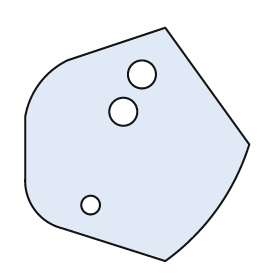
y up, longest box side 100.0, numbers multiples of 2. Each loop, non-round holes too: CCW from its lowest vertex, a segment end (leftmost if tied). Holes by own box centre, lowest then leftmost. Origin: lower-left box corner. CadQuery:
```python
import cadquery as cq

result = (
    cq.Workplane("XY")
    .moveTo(60.0, 0.0)
    .threePointArc((82.0, 22.0), (96.0, 50.0))
    .lineTo(60.0, 100.0)
    .lineTo(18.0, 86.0)
    .threePointArc((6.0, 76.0), (0.0, 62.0))
    .lineTo(0.0, 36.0)
    .threePointArc((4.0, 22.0), (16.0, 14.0))
    .close()
    .moveTo(28.0, 24.0)
    .circle(4.0)
    .moveTo(42.0, 64.0)
    .circle(6.0)
    .moveTo(50.0, 80.0)
    .circle(6.0)
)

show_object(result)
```